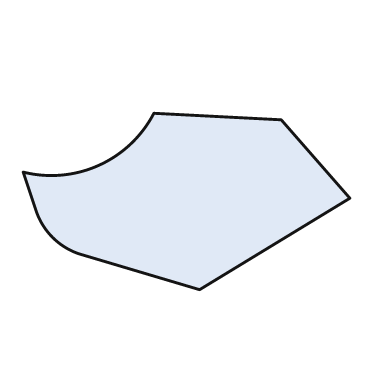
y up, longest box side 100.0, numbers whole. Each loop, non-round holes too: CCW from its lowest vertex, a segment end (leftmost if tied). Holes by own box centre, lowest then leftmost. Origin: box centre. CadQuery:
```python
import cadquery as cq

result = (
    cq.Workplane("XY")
    .moveTo(4.0, -27.0)
    .lineTo(50.0, 1.0)
    .lineTo(29.0, 25.0)
    .lineTo(-10.0, 27.0)
    .threePointArc((-27.0, 11.0), (-50.0, 9.0))
    .lineTo(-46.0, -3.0)
    .threePointArc((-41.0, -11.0), (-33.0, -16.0))
    .close()
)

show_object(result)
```